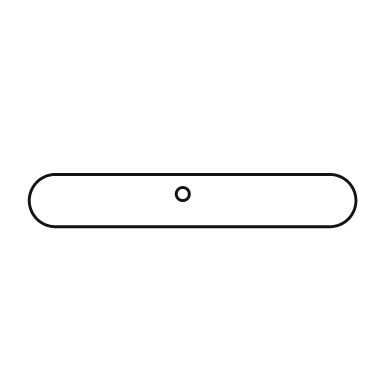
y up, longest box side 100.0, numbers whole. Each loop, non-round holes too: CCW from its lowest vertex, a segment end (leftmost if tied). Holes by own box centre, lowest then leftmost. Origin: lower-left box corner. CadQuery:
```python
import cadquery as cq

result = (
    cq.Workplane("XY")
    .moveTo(8.0, 0.0)
    .lineTo(92.0, 0.0)
    .threePointArc((100.0, 8.0), (92.0, 16.0))
    .lineTo(8.0, 16.0)
    .threePointArc((0.0, 8.0), (8.0, 0.0))
    .close()
    .moveTo(47.0, 10.0)
    .circle(2.0)
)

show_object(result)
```